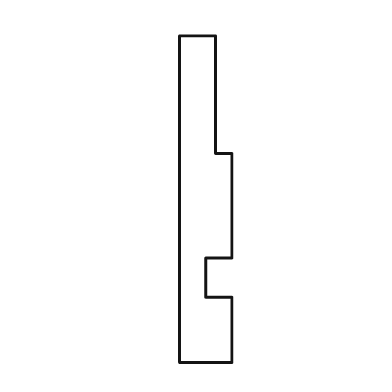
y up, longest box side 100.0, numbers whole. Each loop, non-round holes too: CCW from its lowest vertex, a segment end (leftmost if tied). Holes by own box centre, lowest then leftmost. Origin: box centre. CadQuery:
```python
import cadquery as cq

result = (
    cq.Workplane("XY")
    .moveTo(-8.0, -50.0)
    .lineTo(8.0, -50.0)
    .lineTo(8.0, -30.0)
    .lineTo(0.0, -30.0)
    .lineTo(0.0, -18.0)
    .lineTo(8.0, -18.0)
    .lineTo(8.0, 14.0)
    .lineTo(3.0, 14.0)
    .lineTo(3.0, 50.0)
    .lineTo(-8.0, 50.0)
    .close()
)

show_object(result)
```